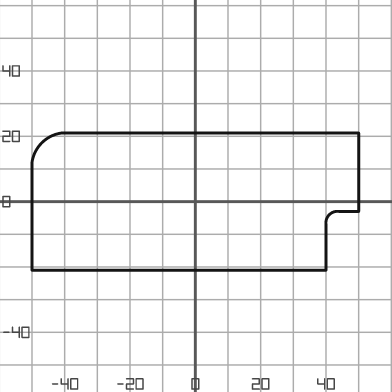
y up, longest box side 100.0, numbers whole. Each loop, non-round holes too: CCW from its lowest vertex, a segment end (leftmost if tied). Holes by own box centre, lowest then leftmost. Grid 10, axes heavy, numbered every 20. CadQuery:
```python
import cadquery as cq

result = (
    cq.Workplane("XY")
    .moveTo(-50.0, -21.0)
    .lineTo(40.0, -21.0)
    .lineTo(40.0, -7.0)
    .threePointArc((41.0, -4.0), (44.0, -3.0))
    .lineTo(50.0, -3.0)
    .lineTo(50.0, 21.0)
    .lineTo(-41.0, 21.0)
    .threePointArc((-47.0, 18.0), (-50.0, 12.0))
    .close()
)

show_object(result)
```